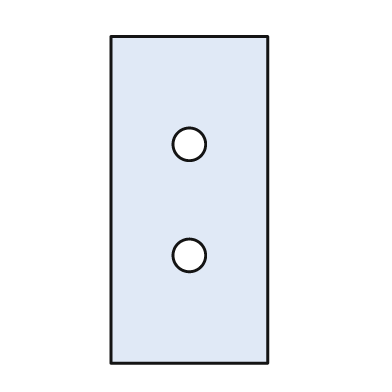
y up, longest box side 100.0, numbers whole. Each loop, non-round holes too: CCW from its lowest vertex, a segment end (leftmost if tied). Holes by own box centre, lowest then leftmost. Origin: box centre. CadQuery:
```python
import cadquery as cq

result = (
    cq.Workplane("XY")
    .moveTo(-24.0, -50.0)
    .lineTo(24.0, -50.0)
    .lineTo(24.0, 50.0)
    .lineTo(-24.0, 50.0)
    .close()
    .moveTo(0.0, -17.0)
    .circle(5.0)
    .moveTo(0.0, 17.0)
    .circle(5.0)
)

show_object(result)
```